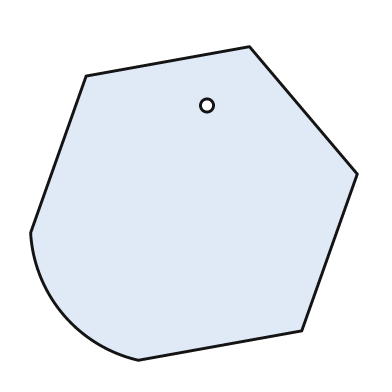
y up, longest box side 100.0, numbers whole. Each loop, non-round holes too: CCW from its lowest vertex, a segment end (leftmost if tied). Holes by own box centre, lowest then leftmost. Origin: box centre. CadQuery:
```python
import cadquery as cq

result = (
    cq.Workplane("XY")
    .moveTo(-17.0, -48.0)
    .lineTo(33.0, -39.0)
    .lineTo(50.0, 9.0)
    .lineTo(17.0, 48.0)
    .lineTo(-33.0, 39.0)
    .lineTo(-50.0, -9.0)
    .threePointArc((-40.0, -34.0), (-17.0, -48.0))
    .close()
    .moveTo(4.0, 30.0)
    .circle(2.0)
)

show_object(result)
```